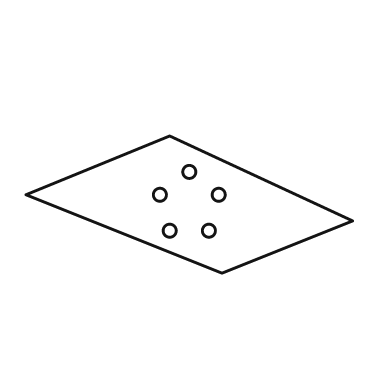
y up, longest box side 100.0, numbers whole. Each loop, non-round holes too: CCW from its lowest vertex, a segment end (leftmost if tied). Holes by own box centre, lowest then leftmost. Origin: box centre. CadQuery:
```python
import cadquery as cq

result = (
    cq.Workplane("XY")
    .moveTo(10.0, -21.0)
    .lineTo(50.0, -5.0)
    .lineTo(-6.0, 21.0)
    .lineTo(-50.0, 3.0)
    .close()
    .moveTo(-6.0, -8.0)
    .circle(2.0)
    .moveTo(6.0, -8.0)
    .circle(2.0)
    .moveTo(-9.0, 3.0)
    .circle(2.0)
    .moveTo(9.0, 3.0)
    .circle(2.0)
    .moveTo(0.0, 10.0)
    .circle(2.0)
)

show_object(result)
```